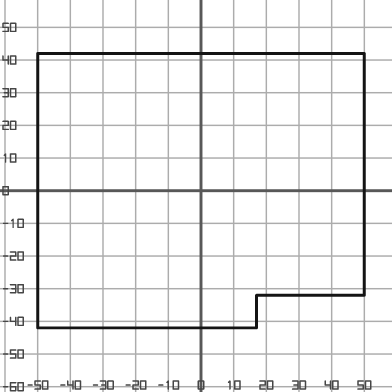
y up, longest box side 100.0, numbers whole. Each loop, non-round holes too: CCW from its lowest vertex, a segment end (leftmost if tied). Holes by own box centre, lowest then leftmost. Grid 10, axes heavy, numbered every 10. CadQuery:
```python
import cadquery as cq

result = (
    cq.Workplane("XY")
    .moveTo(-50.0, -42.0)
    .lineTo(17.0, -42.0)
    .lineTo(17.0, -32.0)
    .lineTo(50.0, -32.0)
    .lineTo(50.0, 42.0)
    .lineTo(-50.0, 42.0)
    .close()
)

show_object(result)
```